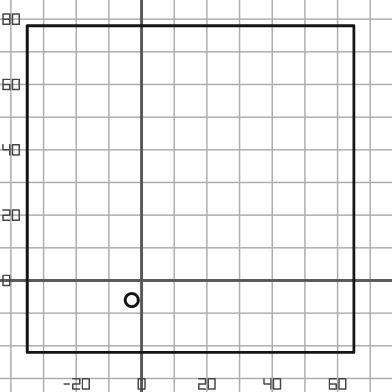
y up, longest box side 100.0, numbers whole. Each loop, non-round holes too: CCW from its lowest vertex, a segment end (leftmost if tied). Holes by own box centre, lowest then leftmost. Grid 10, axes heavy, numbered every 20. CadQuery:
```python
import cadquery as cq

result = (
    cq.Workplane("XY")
    .moveTo(-35.0, -22.0)
    .lineTo(65.0, -22.0)
    .lineTo(65.0, 78.0)
    .lineTo(-35.0, 78.0)
    .close()
    .moveTo(-3.0, -6.0)
    .circle(2.0)
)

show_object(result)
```